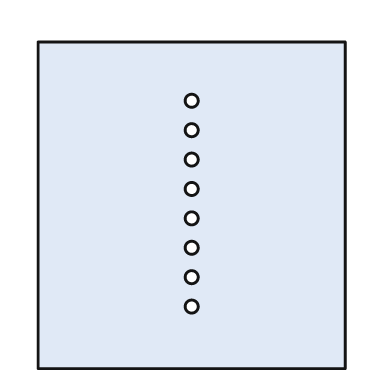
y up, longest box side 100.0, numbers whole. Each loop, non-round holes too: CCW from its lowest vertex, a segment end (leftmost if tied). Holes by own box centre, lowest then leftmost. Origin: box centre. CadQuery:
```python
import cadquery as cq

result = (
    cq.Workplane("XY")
    .moveTo(-47.0, -50.0)
    .lineTo(47.0, -50.0)
    .lineTo(47.0, 50.0)
    .lineTo(-47.0, 50.0)
    .close()
    .moveTo(0.0, -31.0)
    .circle(2.0)
    .moveTo(0.0, -22.0)
    .circle(2.0)
    .moveTo(0.0, -13.0)
    .circle(2.0)
    .moveTo(0.0, -4.0)
    .circle(2.0)
    .moveTo(0.0, 5.0)
    .circle(2.0)
    .moveTo(0.0, 14.0)
    .circle(2.0)
    .moveTo(0.0, 23.0)
    .circle(2.0)
    .moveTo(0.0, 32.0)
    .circle(2.0)
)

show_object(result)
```